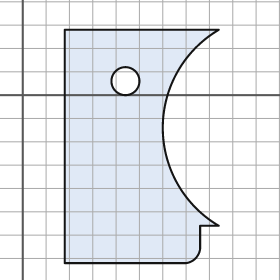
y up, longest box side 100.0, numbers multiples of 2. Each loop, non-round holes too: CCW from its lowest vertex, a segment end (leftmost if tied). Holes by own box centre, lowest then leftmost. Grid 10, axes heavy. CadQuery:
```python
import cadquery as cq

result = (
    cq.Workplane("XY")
    .moveTo(18.0, -72.0)
    .lineTo(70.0, -72.0)
    .threePointArc((74.0, -70.0), (76.0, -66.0))
    .lineTo(76.0, -56.0)
    .lineTo(84.0, -56.0)
    .threePointArc((60.0, -14.0), (84.0, 28.0))
    .lineTo(18.0, 28.0)
    .close()
    .moveTo(44.0, 6.0)
    .circle(6.0)
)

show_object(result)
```